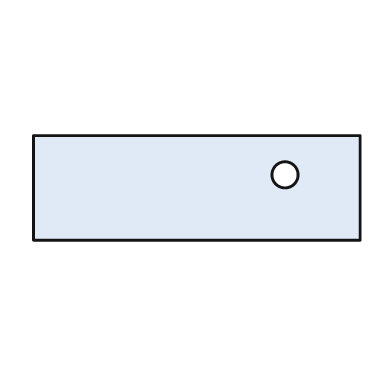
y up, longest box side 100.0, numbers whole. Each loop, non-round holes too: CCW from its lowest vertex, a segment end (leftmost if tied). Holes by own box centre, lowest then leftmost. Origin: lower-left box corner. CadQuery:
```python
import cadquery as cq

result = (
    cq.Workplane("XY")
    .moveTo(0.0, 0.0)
    .lineTo(100.0, 0.0)
    .lineTo(100.0, 32.0)
    .lineTo(0.0, 32.0)
    .close()
    .moveTo(77.0, 20.0)
    .circle(4.0)
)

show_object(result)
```